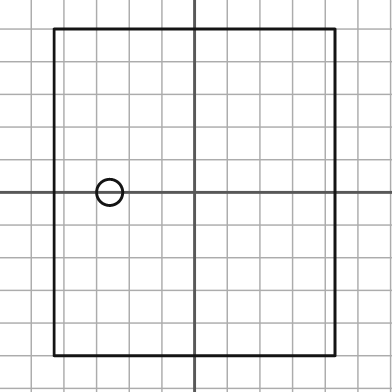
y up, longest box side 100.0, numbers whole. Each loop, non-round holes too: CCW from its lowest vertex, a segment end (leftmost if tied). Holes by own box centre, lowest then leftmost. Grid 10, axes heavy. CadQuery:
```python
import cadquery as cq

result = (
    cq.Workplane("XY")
    .moveTo(-43.0, -50.0)
    .lineTo(43.0, -50.0)
    .lineTo(43.0, 50.0)
    .lineTo(-43.0, 50.0)
    .close()
    .moveTo(-26.0, 0.0)
    .circle(4.0)
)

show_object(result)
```